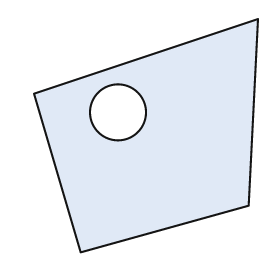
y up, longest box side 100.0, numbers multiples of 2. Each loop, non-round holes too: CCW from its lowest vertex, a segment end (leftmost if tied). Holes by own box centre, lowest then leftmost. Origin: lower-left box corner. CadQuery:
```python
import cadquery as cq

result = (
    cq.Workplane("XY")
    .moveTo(20.0, 0.0)
    .lineTo(92.0, 20.0)
    .lineTo(96.0, 100.0)
    .lineTo(0.0, 68.0)
    .close()
    .moveTo(36.0, 60.0)
    .circle(12.0)
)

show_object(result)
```